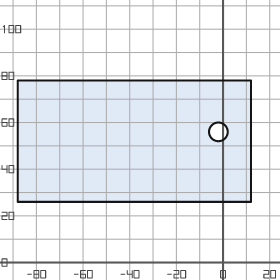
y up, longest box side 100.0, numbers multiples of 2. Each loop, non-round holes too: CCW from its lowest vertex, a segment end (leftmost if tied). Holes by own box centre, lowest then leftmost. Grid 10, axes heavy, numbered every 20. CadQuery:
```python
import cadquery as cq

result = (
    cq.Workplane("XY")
    .moveTo(-88.0, 26.0)
    .lineTo(12.0, 26.0)
    .lineTo(12.0, 78.0)
    .lineTo(-88.0, 78.0)
    .close()
    .moveTo(-2.0, 56.0)
    .circle(4.0)
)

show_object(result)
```